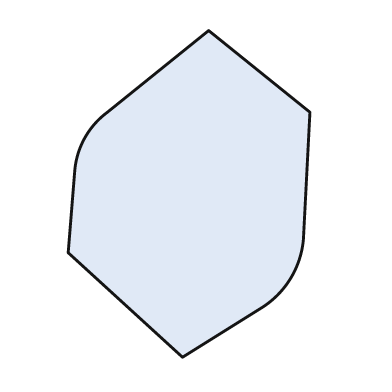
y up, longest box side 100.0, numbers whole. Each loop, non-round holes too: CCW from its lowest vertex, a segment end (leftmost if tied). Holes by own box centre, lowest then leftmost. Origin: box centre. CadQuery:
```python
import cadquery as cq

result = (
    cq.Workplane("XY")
    .moveTo(-2.0, -50.0)
    .lineTo(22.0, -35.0)
    .threePointArc((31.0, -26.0), (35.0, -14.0))
    .lineTo(37.0, 25.0)
    .lineTo(6.0, 50.0)
    .lineTo(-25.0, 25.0)
    .threePointArc((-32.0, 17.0), (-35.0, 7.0))
    .lineTo(-37.0, -18.0)
    .close()
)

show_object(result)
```